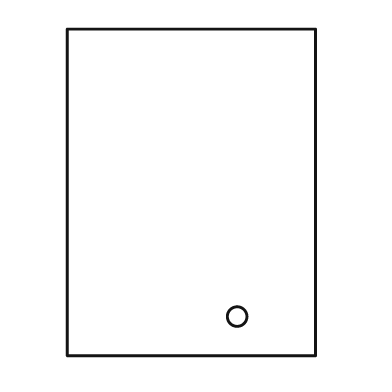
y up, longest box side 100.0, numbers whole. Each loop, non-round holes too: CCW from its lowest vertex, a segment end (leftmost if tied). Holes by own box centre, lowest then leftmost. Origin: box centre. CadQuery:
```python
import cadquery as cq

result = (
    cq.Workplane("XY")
    .moveTo(-38.0, -50.0)
    .lineTo(38.0, -50.0)
    .lineTo(38.0, 50.0)
    .lineTo(-38.0, 50.0)
    .close()
    .moveTo(14.0, -38.0)
    .circle(3.0)
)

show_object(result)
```